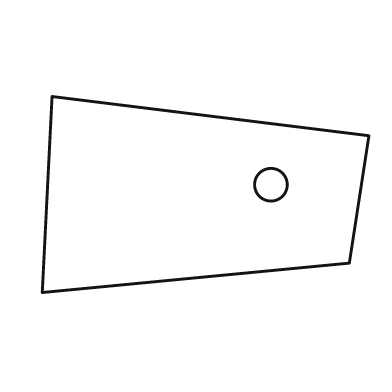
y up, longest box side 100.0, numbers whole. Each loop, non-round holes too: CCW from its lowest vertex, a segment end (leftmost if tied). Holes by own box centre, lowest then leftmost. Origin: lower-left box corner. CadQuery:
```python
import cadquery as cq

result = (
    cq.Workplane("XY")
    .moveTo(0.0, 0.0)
    .lineTo(94.0, 9.0)
    .lineTo(100.0, 48.0)
    .lineTo(3.0, 60.0)
    .close()
    .moveTo(70.0, 33.0)
    .circle(5.0)
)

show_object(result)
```